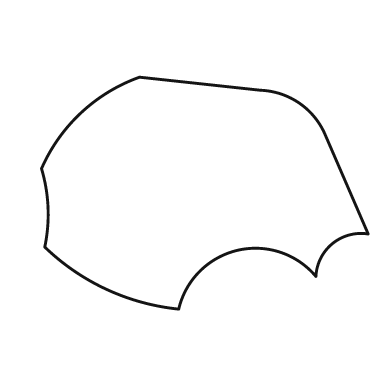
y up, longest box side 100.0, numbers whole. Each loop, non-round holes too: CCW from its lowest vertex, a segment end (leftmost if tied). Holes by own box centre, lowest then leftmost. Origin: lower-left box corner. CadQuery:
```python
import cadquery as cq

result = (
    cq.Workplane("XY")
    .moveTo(42.0, 0.0)
    .threePointArc((60.0, 18.0), (84.0, 10.0))
    .threePointArc((89.0, 20.0), (100.0, 23.0))
    .lineTo(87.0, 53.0)
    .threePointArc((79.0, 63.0), (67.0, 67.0))
    .lineTo(30.0, 71.0)
    .threePointArc((12.0, 60.0), (0.0, 43.0))
    .threePointArc((2.0, 31.0), (1.0, 19.0))
    .threePointArc((20.0, 6.0), (42.0, 0.0))
    .close()
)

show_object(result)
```